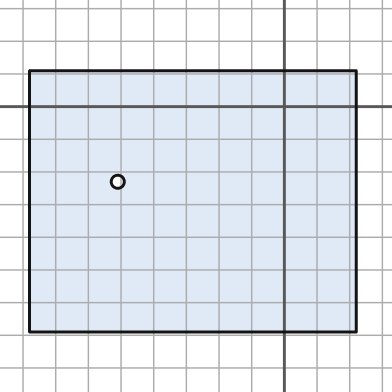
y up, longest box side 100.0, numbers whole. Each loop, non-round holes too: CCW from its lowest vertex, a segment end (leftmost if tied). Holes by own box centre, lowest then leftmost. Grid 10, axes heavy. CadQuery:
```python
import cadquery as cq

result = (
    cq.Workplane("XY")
    .moveTo(-78.0, -69.0)
    .lineTo(22.0, -69.0)
    .lineTo(22.0, 11.0)
    .lineTo(-78.0, 11.0)
    .close()
    .moveTo(-51.0, -23.0)
    .circle(2.0)
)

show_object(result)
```